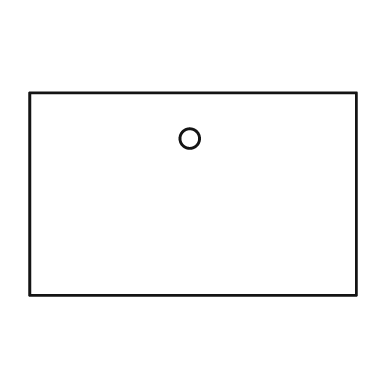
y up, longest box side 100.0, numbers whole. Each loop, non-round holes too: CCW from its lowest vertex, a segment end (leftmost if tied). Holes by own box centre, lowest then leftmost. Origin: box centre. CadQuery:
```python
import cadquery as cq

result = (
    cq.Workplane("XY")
    .moveTo(-50.0, -31.0)
    .lineTo(50.0, -31.0)
    .lineTo(50.0, 31.0)
    .lineTo(-50.0, 31.0)
    .close()
    .moveTo(-1.0, 17.0)
    .circle(3.0)
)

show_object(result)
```